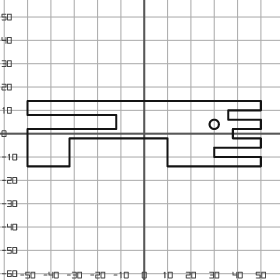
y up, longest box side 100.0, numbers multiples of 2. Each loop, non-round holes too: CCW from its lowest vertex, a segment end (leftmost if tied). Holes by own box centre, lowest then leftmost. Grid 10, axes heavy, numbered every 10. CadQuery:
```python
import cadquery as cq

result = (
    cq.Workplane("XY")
    .moveTo(-50.0, -14.0)
    .lineTo(-32.0, -14.0)
    .lineTo(-32.0, -2.0)
    .lineTo(10.0, -2.0)
    .lineTo(10.0, -14.0)
    .lineTo(50.0, -14.0)
    .lineTo(50.0, -10.0)
    .lineTo(30.0, -10.0)
    .lineTo(30.0, -6.0)
    .lineTo(50.0, -6.0)
    .lineTo(50.0, -2.0)
    .lineTo(38.0, -2.0)
    .lineTo(38.0, 2.0)
    .lineTo(50.0, 2.0)
    .lineTo(50.0, 6.0)
    .lineTo(36.0, 6.0)
    .lineTo(36.0, 10.0)
    .lineTo(50.0, 10.0)
    .lineTo(50.0, 14.0)
    .lineTo(-50.0, 14.0)
    .lineTo(-50.0, 8.0)
    .lineTo(-12.0, 8.0)
    .lineTo(-12.0, 2.0)
    .lineTo(-50.0, 2.0)
    .close()
    .moveTo(30.0, 4.0)
    .circle(2.0)
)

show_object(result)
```